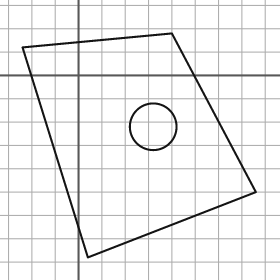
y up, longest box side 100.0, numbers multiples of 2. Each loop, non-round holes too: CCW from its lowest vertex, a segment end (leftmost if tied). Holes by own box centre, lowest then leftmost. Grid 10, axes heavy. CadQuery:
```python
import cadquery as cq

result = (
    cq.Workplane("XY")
    .moveTo(4.0, -78.0)
    .lineTo(76.0, -50.0)
    .lineTo(40.0, 18.0)
    .lineTo(-24.0, 12.0)
    .close()
    .moveTo(32.0, -22.0)
    .circle(10.0)
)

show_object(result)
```